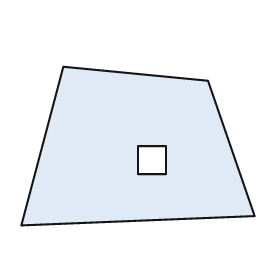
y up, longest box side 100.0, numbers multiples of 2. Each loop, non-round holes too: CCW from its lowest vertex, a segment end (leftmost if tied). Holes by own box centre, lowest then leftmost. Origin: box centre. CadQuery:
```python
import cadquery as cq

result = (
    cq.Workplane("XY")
    .moveTo(-50.0, -34.0)
    .lineTo(50.0, -30.0)
    .lineTo(30.0, 28.0)
    .lineTo(-32.0, 34.0)
    .close()
    .moveTo(0.0, -12.0)
    .lineTo(12.0, -12.0)
    .lineTo(12.0, 0.0)
    .lineTo(0.0, 0.0)
    .close()
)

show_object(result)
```